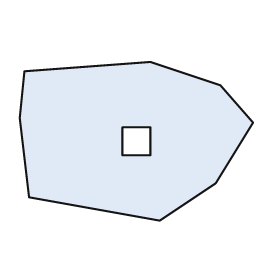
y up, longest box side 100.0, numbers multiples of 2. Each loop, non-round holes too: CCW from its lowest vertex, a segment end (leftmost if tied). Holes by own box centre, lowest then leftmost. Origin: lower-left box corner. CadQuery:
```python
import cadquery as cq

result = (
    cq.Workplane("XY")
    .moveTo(60.0, 0.0)
    .lineTo(84.0, 16.0)
    .lineTo(100.0, 42.0)
    .lineTo(86.0, 58.0)
    .lineTo(56.0, 68.0)
    .lineTo(2.0, 64.0)
    .lineTo(0.0, 44.0)
    .lineTo(4.0, 10.0)
    .close()
    .moveTo(44.0, 28.0)
    .lineTo(56.0, 28.0)
    .lineTo(56.0, 40.0)
    .lineTo(44.0, 40.0)
    .close()
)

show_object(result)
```